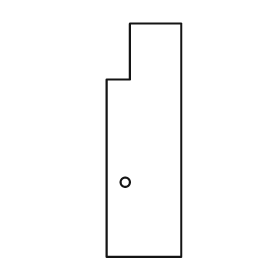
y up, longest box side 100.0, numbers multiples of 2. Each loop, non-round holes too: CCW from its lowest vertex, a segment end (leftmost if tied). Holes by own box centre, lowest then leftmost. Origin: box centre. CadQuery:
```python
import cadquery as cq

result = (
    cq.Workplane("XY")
    .moveTo(-16.0, -50.0)
    .lineTo(16.0, -50.0)
    .lineTo(16.0, 50.0)
    .lineTo(-6.0, 50.0)
    .lineTo(-6.0, 26.0)
    .lineTo(-16.0, 26.0)
    .close()
    .moveTo(-8.0, -18.0)
    .circle(2.0)
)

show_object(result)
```